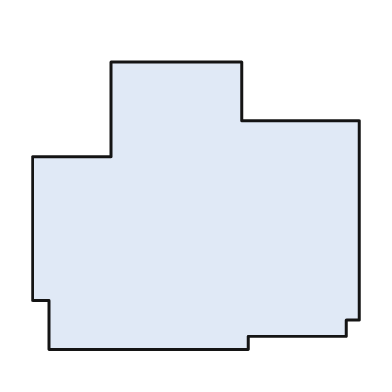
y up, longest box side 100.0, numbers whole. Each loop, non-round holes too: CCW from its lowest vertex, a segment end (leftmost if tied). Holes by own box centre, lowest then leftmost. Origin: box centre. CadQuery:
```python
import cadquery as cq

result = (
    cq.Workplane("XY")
    .moveTo(-45.0, -44.0)
    .lineTo(16.0, -44.0)
    .lineTo(16.0, -40.0)
    .lineTo(46.0, -40.0)
    .lineTo(46.0, -35.0)
    .lineTo(50.0, -35.0)
    .lineTo(50.0, 26.0)
    .lineTo(14.0, 26.0)
    .lineTo(14.0, 44.0)
    .lineTo(-26.0, 44.0)
    .lineTo(-26.0, 15.0)
    .lineTo(-50.0, 15.0)
    .lineTo(-50.0, -29.0)
    .lineTo(-45.0, -29.0)
    .close()
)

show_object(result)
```